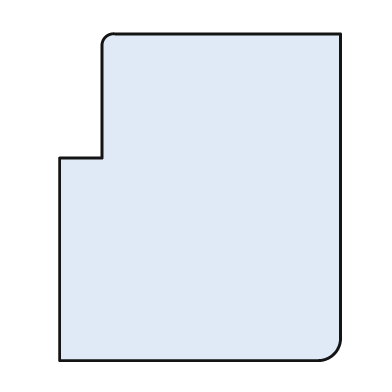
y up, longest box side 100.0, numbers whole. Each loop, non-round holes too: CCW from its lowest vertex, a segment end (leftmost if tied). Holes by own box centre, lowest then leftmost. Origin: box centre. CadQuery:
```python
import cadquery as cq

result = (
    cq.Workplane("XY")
    .moveTo(-43.0, -50.0)
    .lineTo(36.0, -50.0)
    .threePointArc((41.0, -48.0), (43.0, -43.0))
    .lineTo(43.0, 50.0)
    .lineTo(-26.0, 50.0)
    .threePointArc((-29.0, 49.0), (-30.0, 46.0))
    .lineTo(-30.0, 12.0)
    .lineTo(-43.0, 12.0)
    .close()
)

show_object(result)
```